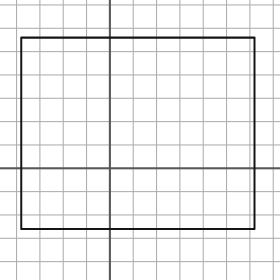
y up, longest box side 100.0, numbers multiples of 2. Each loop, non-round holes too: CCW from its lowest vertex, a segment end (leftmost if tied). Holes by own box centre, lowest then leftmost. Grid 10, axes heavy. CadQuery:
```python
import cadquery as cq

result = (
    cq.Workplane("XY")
    .moveTo(-38.0, -26.0)
    .lineTo(62.0, -26.0)
    .lineTo(62.0, 56.0)
    .lineTo(-38.0, 56.0)
    .close()
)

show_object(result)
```